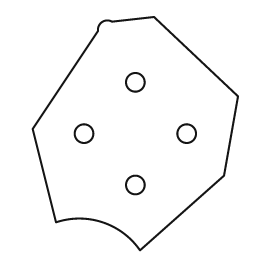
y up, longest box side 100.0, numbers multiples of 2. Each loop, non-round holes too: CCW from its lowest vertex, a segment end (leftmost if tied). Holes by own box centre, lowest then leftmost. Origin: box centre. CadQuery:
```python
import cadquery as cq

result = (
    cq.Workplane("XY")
    .moveTo(2.0, -50.0)
    .lineTo(38.0, -18.0)
    .lineTo(44.0, 16.0)
    .lineTo(8.0, 50.0)
    .lineTo(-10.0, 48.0)
    .threePointArc((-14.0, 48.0), (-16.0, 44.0))
    .lineTo(-44.0, 2.0)
    .lineTo(-34.0, -38.0)
    .threePointArc((-14.0, -38.0), (2.0, -50.0))
    .close()
    .moveTo(0.0, -22.0)
    .circle(4.0)
    .moveTo(-22.0, 0.0)
    .circle(4.0)
    .moveTo(22.0, 0.0)
    .circle(4.0)
    .moveTo(0.0, 22.0)
    .circle(4.0)
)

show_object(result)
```